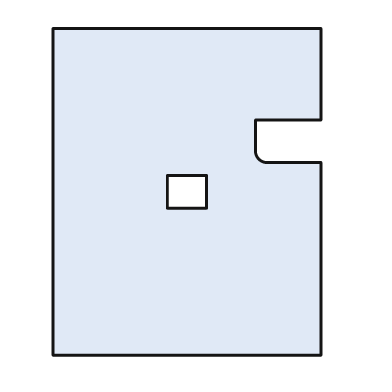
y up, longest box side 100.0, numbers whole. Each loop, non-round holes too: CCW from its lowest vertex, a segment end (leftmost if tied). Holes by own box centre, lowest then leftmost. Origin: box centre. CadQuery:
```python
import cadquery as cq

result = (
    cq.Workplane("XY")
    .moveTo(-41.0, -50.0)
    .lineTo(41.0, -50.0)
    .lineTo(41.0, 9.0)
    .lineTo(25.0, 9.0)
    .threePointArc((22.0, 10.0), (21.0, 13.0))
    .lineTo(21.0, 22.0)
    .lineTo(41.0, 22.0)
    .lineTo(41.0, 50.0)
    .lineTo(-41.0, 50.0)
    .close()
    .moveTo(-6.0, -5.0)
    .lineTo(6.0, -5.0)
    .lineTo(6.0, 5.0)
    .lineTo(-6.0, 5.0)
    .close()
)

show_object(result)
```